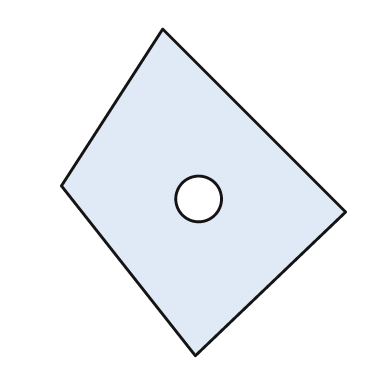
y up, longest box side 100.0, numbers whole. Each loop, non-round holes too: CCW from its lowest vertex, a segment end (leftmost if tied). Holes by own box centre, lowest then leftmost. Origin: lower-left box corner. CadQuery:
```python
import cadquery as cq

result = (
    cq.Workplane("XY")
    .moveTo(41.0, 0.0)
    .lineTo(87.0, 44.0)
    .lineTo(31.0, 100.0)
    .lineTo(0.0, 52.0)
    .close()
    .moveTo(42.0, 48.0)
    .circle(7.0)
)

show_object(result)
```